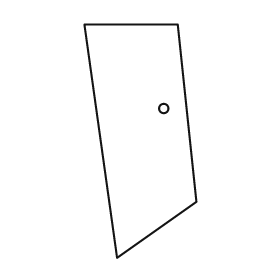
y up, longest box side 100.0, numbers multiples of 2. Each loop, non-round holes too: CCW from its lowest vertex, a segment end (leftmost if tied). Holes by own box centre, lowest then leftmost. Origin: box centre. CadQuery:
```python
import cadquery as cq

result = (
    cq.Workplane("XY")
    .moveTo(-10.0, -50.0)
    .lineTo(24.0, -26.0)
    .lineTo(16.0, 50.0)
    .lineTo(-24.0, 50.0)
    .close()
    .moveTo(10.0, 14.0)
    .circle(2.0)
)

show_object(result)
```